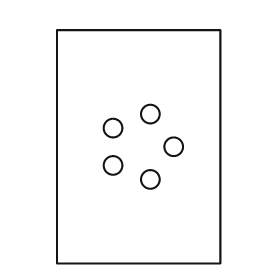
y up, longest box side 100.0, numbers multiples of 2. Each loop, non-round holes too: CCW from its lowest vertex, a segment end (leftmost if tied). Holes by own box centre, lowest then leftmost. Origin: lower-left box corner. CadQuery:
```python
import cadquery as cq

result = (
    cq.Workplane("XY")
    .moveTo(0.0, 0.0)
    .lineTo(70.0, 0.0)
    .lineTo(70.0, 100.0)
    .lineTo(0.0, 100.0)
    .close()
    .moveTo(40.0, 36.0)
    .circle(4.0)
    .moveTo(24.0, 42.0)
    .circle(4.0)
    .moveTo(50.0, 50.0)
    .circle(4.0)
    .moveTo(24.0, 58.0)
    .circle(4.0)
    .moveTo(40.0, 64.0)
    .circle(4.0)
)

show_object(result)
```